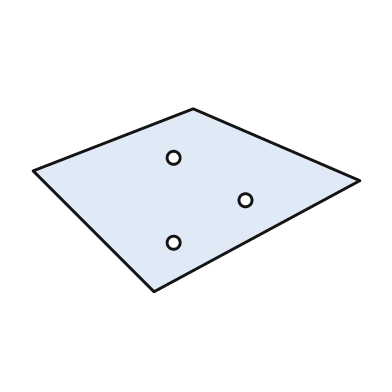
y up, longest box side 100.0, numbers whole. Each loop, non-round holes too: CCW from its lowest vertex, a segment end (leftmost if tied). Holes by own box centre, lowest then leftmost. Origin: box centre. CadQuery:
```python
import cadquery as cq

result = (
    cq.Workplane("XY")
    .moveTo(-13.0, -28.0)
    .lineTo(50.0, 6.0)
    .lineTo(-1.0, 28.0)
    .lineTo(-50.0, 9.0)
    .close()
    .moveTo(-7.0, -13.0)
    .circle(2.0)
    .moveTo(15.0, 0.0)
    .circle(2.0)
    .moveTo(-7.0, 13.0)
    .circle(2.0)
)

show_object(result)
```